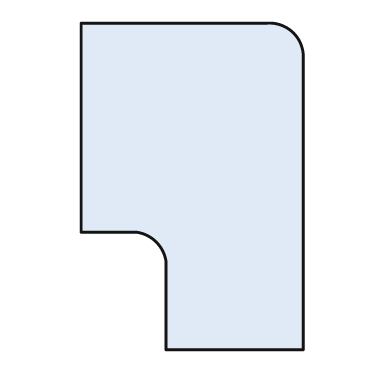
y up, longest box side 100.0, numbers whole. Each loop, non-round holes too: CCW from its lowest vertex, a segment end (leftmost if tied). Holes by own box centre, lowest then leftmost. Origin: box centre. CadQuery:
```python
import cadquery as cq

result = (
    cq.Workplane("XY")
    .moveTo(-8.0, -50.0)
    .lineTo(34.0, -50.0)
    .lineTo(34.0, 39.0)
    .threePointArc((31.0, 47.0), (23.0, 50.0))
    .lineTo(-34.0, 50.0)
    .lineTo(-34.0, -14.0)
    .lineTo(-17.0, -14.0)
    .threePointArc((-11.0, -17.0), (-8.0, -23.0))
    .close()
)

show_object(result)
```